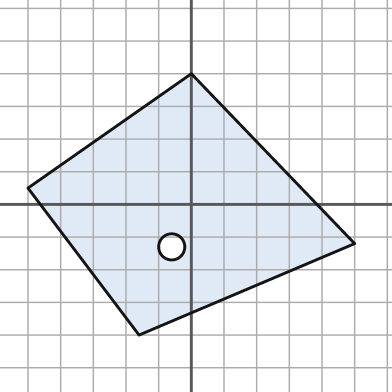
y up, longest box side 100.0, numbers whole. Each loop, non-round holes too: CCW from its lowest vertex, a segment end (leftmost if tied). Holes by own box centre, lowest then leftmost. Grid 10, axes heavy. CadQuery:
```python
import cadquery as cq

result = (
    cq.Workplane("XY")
    .moveTo(-16.0, -40.0)
    .lineTo(50.0, -12.0)
    .lineTo(0.0, 40.0)
    .lineTo(-50.0, 5.0)
    .close()
    .moveTo(-6.0, -13.0)
    .circle(4.0)
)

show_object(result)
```